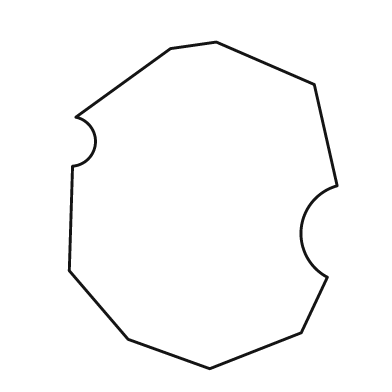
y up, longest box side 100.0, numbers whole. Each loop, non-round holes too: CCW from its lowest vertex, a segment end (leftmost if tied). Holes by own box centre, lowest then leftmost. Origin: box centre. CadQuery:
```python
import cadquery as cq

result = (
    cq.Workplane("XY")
    .moveTo(2.0, -50.0)
    .lineTo(30.0, -39.0)
    .lineTo(38.0, -22.0)
    .threePointArc((30.0, -7.0), (41.0, 6.0))
    .lineTo(34.0, 37.0)
    .lineTo(4.0, 50.0)
    .lineTo(-10.0, 48.0)
    .lineTo(-39.0, 27.0)
    .threePointArc((-33.0, 19.0), (-40.0, 12.0))
    .lineTo(-41.0, -20.0)
    .lineTo(-23.0, -41.0)
    .close()
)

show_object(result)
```